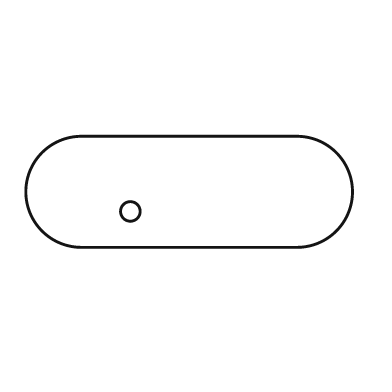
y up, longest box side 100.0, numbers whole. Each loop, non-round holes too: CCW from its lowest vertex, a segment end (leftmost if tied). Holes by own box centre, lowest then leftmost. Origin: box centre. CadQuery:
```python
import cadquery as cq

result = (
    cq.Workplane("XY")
    .moveTo(-33.0, -17.0)
    .lineTo(33.0, -17.0)
    .threePointArc((50.0, 0.0), (33.0, 17.0))
    .lineTo(-33.0, 17.0)
    .threePointArc((-50.0, 0.0), (-33.0, -17.0))
    .close()
    .moveTo(-18.0, -6.0)
    .circle(3.0)
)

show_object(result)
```